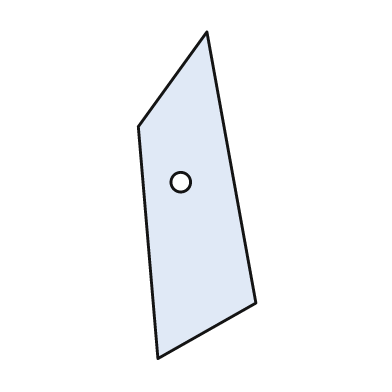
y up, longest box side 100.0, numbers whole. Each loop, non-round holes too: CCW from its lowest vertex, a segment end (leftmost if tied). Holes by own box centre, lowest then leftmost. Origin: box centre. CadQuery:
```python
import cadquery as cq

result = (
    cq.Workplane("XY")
    .moveTo(-12.0, -50.0)
    .lineTo(18.0, -33.0)
    .lineTo(3.0, 50.0)
    .lineTo(-18.0, 21.0)
    .close()
    .moveTo(-5.0, 4.0)
    .circle(3.0)
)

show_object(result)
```